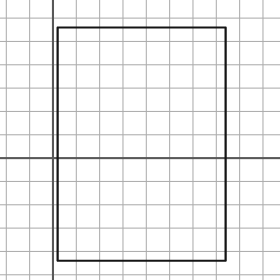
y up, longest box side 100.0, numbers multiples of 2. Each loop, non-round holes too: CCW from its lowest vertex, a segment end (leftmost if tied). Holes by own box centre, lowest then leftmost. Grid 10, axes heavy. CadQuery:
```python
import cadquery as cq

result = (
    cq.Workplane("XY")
    .moveTo(2.0, -44.0)
    .lineTo(74.0, -44.0)
    .lineTo(74.0, 56.0)
    .lineTo(2.0, 56.0)
    .close()
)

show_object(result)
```